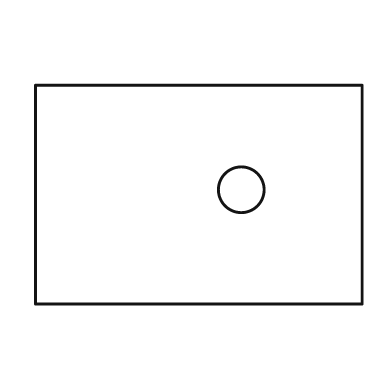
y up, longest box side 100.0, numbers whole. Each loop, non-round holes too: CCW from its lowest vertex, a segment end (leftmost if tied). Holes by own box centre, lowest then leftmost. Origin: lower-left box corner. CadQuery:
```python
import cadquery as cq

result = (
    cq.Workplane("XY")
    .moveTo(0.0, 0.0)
    .lineTo(100.0, 0.0)
    .lineTo(100.0, 67.0)
    .lineTo(0.0, 67.0)
    .close()
    .moveTo(63.0, 35.0)
    .circle(7.0)
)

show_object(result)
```